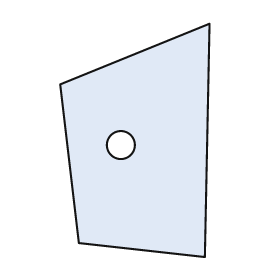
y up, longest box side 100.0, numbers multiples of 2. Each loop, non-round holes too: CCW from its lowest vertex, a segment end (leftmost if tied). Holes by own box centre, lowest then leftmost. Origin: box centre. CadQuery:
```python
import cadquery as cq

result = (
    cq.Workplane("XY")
    .moveTo(30.0, -50.0)
    .lineTo(32.0, 50.0)
    .lineTo(-32.0, 24.0)
    .lineTo(-24.0, -44.0)
    .close()
    .moveTo(-6.0, -2.0)
    .circle(6.0)
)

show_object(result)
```